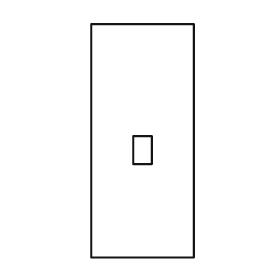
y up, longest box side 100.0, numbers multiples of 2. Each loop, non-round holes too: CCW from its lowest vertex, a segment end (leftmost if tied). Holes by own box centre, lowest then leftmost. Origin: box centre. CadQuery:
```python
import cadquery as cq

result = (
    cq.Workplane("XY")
    .moveTo(-22.0, -50.0)
    .lineTo(22.0, -50.0)
    .lineTo(22.0, 50.0)
    .lineTo(-22.0, 50.0)
    .close()
    .moveTo(-4.0, -10.0)
    .lineTo(4.0, -10.0)
    .lineTo(4.0, 2.0)
    .lineTo(-4.0, 2.0)
    .close()
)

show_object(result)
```